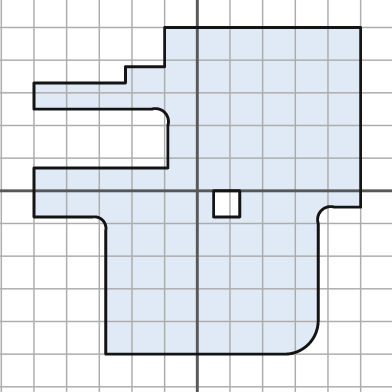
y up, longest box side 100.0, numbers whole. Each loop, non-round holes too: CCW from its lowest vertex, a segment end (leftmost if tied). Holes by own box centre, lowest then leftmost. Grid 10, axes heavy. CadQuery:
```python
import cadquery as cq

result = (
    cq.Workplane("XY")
    .moveTo(-28.0, -50.0)
    .lineTo(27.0, -50.0)
    .threePointArc((34.0, -47.0), (37.0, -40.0))
    .lineTo(37.0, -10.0)
    .threePointArc((38.0, -6.0), (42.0, -5.0))
    .lineTo(50.0, -5.0)
    .lineTo(50.0, 50.0)
    .lineTo(-10.0, 50.0)
    .lineTo(-10.0, 38.0)
    .lineTo(-22.0, 38.0)
    .lineTo(-22.0, 33.0)
    .lineTo(-50.0, 33.0)
    .lineTo(-50.0, 25.0)
    .lineTo(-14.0, 25.0)
    .threePointArc((-10.0, 24.0), (-9.0, 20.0))
    .lineTo(-9.0, 7.0)
    .lineTo(-50.0, 7.0)
    .lineTo(-50.0, -8.0)
    .lineTo(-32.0, -8.0)
    .threePointArc((-29.0, -9.0), (-28.0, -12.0))
    .close()
    .moveTo(5.0, -8.0)
    .lineTo(13.0, -8.0)
    .lineTo(13.0, 0.0)
    .lineTo(5.0, 0.0)
    .close()
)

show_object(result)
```